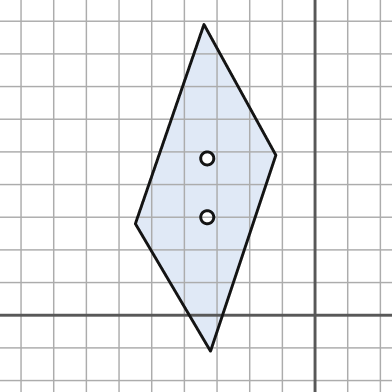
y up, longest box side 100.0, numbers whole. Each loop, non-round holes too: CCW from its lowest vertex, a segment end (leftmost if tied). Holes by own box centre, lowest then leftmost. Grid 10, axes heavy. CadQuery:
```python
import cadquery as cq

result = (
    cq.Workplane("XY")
    .moveTo(-32.0, -11.0)
    .lineTo(-12.0, 49.0)
    .lineTo(-34.0, 89.0)
    .lineTo(-55.0, 28.0)
    .close()
    .moveTo(-33.0, 30.0)
    .circle(2.0)
    .moveTo(-33.0, 48.0)
    .circle(2.0)
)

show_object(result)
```